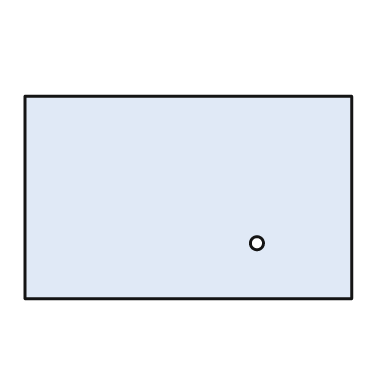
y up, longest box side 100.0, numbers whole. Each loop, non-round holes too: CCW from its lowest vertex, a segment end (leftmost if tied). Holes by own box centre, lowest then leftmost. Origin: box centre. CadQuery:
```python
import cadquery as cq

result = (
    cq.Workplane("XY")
    .moveTo(-50.0, -31.0)
    .lineTo(50.0, -31.0)
    .lineTo(50.0, 31.0)
    .lineTo(-50.0, 31.0)
    .close()
    .moveTo(21.0, -14.0)
    .circle(2.0)
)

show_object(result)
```